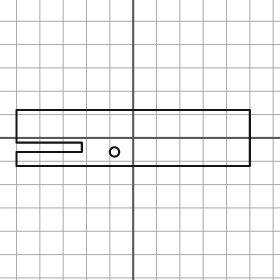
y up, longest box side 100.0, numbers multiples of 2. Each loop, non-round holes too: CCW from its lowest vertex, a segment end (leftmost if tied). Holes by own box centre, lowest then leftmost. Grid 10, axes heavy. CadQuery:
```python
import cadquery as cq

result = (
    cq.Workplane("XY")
    .moveTo(-50.0, -12.0)
    .lineTo(50.0, -12.0)
    .lineTo(50.0, 12.0)
    .lineTo(-50.0, 12.0)
    .lineTo(-50.0, -2.0)
    .lineTo(-22.0, -2.0)
    .lineTo(-22.0, -6.0)
    .lineTo(-50.0, -6.0)
    .close()
    .moveTo(-8.0, -6.0)
    .circle(2.0)
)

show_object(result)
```